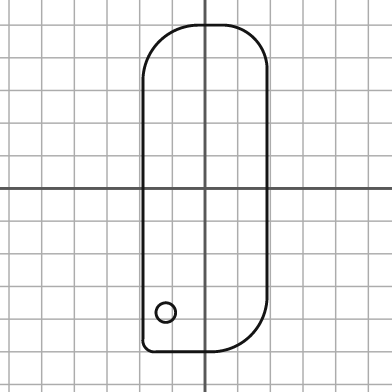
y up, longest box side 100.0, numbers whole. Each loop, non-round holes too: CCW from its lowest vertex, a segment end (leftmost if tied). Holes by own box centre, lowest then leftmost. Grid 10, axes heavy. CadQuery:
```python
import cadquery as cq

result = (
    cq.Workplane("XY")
    .moveTo(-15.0, -50.0)
    .lineTo(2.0, -50.0)
    .threePointArc((14.0, -45.0), (19.0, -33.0))
    .lineTo(19.0, 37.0)
    .threePointArc((15.0, 46.0), (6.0, 50.0))
    .lineTo(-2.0, 50.0)
    .threePointArc((-14.0, 45.0), (-19.0, 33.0))
    .lineTo(-19.0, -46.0)
    .threePointArc((-18.0, -49.0), (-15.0, -50.0))
    .close()
    .moveTo(-12.0, -38.0)
    .circle(3.0)
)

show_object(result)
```